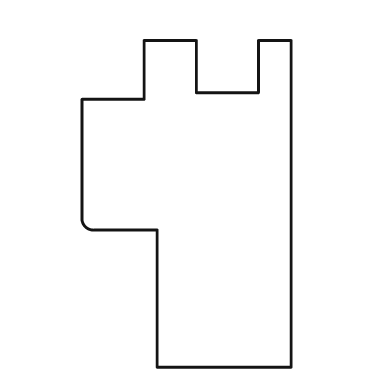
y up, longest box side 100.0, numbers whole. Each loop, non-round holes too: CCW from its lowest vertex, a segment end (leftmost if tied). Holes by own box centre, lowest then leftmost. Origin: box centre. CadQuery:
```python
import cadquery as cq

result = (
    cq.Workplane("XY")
    .moveTo(-9.0, -50.0)
    .lineTo(32.0, -50.0)
    .lineTo(32.0, 50.0)
    .lineTo(22.0, 50.0)
    .lineTo(22.0, 34.0)
    .lineTo(3.0, 34.0)
    .lineTo(3.0, 50.0)
    .lineTo(-13.0, 50.0)
    .lineTo(-13.0, 32.0)
    .lineTo(-32.0, 32.0)
    .lineTo(-32.0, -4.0)
    .threePointArc((-31.0, -7.0), (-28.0, -8.0))
    .lineTo(-9.0, -8.0)
    .close()
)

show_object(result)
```